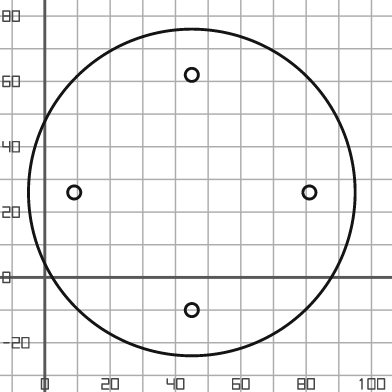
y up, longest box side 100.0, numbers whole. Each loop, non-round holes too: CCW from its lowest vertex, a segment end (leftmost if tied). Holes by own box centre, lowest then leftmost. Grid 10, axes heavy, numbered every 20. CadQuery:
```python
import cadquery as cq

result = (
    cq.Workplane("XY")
    .moveTo(45.0, 26.0)
    .circle(50.0)
    .moveTo(45.0, -10.0)
    .circle(2.0)
    .moveTo(9.0, 26.0)
    .circle(2.0)
    .moveTo(81.0, 26.0)
    .circle(2.0)
    .moveTo(45.0, 62.0)
    .circle(2.0)
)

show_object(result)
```